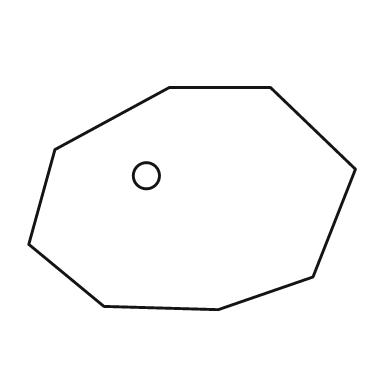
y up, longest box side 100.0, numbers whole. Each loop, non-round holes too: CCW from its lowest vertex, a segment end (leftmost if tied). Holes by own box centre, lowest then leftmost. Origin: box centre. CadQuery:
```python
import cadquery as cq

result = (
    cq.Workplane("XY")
    .moveTo(8.0, -34.0)
    .lineTo(37.0, -24.0)
    .lineTo(50.0, 9.0)
    .lineTo(24.0, 34.0)
    .lineTo(-7.0, 34.0)
    .lineTo(-42.0, 15.0)
    .lineTo(-50.0, -14.0)
    .lineTo(-27.0, -33.0)
    .close()
    .moveTo(-14.0, 7.0)
    .circle(4.0)
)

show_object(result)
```